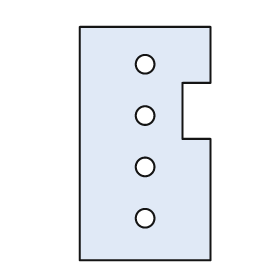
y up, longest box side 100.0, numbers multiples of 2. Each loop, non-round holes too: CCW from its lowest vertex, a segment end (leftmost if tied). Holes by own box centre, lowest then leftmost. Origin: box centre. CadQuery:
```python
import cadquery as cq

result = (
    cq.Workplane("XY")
    .moveTo(-28.0, -50.0)
    .lineTo(28.0, -50.0)
    .lineTo(28.0, 2.0)
    .lineTo(16.0, 2.0)
    .lineTo(16.0, 26.0)
    .lineTo(28.0, 26.0)
    .lineTo(28.0, 50.0)
    .lineTo(-28.0, 50.0)
    .close()
    .moveTo(0.0, -32.0)
    .circle(4.0)
    .moveTo(0.0, -10.0)
    .circle(4.0)
    .moveTo(0.0, 12.0)
    .circle(4.0)
    .moveTo(0.0, 34.0)
    .circle(4.0)
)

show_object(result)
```